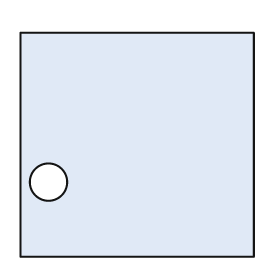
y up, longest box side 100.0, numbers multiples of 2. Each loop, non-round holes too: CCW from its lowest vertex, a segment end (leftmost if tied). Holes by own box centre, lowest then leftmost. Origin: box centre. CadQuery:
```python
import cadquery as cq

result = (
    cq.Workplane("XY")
    .moveTo(-50.0, -48.0)
    .lineTo(50.0, -48.0)
    .lineTo(50.0, 48.0)
    .lineTo(-50.0, 48.0)
    .close()
    .moveTo(-38.0, -16.0)
    .circle(8.0)
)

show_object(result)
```